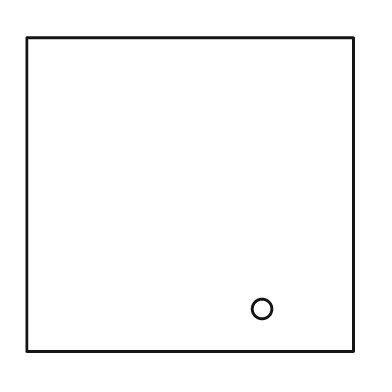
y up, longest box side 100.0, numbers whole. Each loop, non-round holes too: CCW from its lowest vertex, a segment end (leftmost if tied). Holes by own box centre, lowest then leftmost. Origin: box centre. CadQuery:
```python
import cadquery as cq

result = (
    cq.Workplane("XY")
    .moveTo(-50.0, -48.0)
    .lineTo(50.0, -48.0)
    .lineTo(50.0, 48.0)
    .lineTo(-50.0, 48.0)
    .close()
    .moveTo(22.0, -35.0)
    .circle(3.0)
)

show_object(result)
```